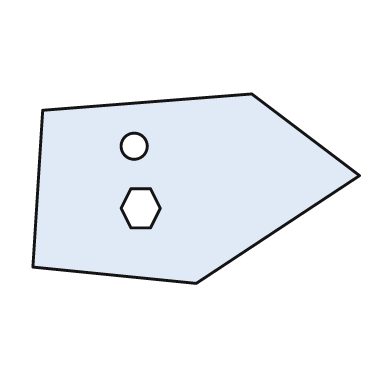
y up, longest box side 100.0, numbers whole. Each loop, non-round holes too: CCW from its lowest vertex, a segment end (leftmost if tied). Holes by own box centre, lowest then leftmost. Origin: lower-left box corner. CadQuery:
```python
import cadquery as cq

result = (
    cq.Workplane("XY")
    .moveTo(50.0, 0.0)
    .lineTo(100.0, 33.0)
    .lineTo(67.0, 58.0)
    .lineTo(3.0, 53.0)
    .lineTo(0.0, 5.0)
    .close()
    .moveTo(30.0, 17.0)
    .lineTo(36.0, 17.0)
    .lineTo(39.0, 23.0)
    .lineTo(36.0, 29.0)
    .lineTo(30.0, 29.0)
    .lineTo(27.0, 23.0)
    .close()
    .moveTo(31.0, 42.0)
    .circle(4.0)
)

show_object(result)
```